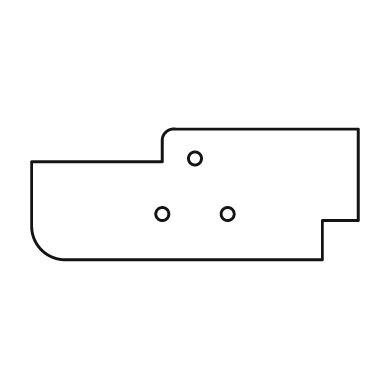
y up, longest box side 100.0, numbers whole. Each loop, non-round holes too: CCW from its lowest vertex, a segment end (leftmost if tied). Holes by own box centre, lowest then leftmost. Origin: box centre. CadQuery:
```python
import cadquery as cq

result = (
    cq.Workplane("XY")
    .moveTo(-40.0, -20.0)
    .lineTo(39.0, -20.0)
    .lineTo(39.0, -8.0)
    .lineTo(50.0, -8.0)
    .lineTo(50.0, 20.0)
    .lineTo(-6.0, 20.0)
    .threePointArc((-9.0, 19.0), (-10.0, 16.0))
    .lineTo(-10.0, 10.0)
    .lineTo(-50.0, 10.0)
    .lineTo(-50.0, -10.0)
    .threePointArc((-47.0, -17.0), (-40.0, -20.0))
    .close()
    .moveTo(-10.0, -6.0)
    .circle(2.0)
    .moveTo(10.0, -6.0)
    .circle(2.0)
    .moveTo(0.0, 11.0)
    .circle(2.0)
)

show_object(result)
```